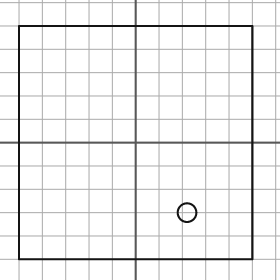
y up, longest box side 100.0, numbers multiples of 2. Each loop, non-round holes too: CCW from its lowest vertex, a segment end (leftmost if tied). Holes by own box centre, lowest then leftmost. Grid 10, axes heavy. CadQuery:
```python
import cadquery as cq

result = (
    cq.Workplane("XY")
    .moveTo(-50.0, -50.0)
    .lineTo(50.0, -50.0)
    .lineTo(50.0, 50.0)
    .lineTo(-50.0, 50.0)
    .close()
    .moveTo(22.0, -30.0)
    .circle(4.0)
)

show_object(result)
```